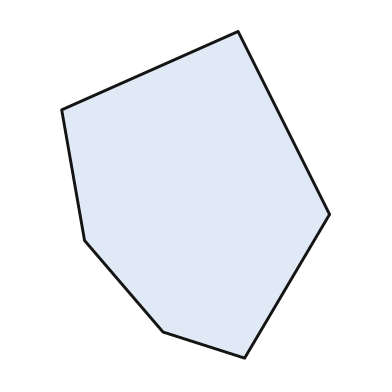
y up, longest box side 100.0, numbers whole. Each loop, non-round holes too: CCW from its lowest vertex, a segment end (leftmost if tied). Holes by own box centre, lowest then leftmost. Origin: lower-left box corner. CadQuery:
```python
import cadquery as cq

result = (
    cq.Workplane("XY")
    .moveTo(56.0, 0.0)
    .lineTo(82.0, 44.0)
    .lineTo(54.0, 100.0)
    .lineTo(0.0, 76.0)
    .lineTo(7.0, 36.0)
    .lineTo(31.0, 8.0)
    .close()
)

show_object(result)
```